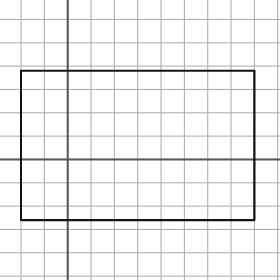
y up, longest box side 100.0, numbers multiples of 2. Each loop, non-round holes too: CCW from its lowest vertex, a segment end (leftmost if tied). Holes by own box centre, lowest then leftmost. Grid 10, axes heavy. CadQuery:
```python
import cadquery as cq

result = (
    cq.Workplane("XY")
    .moveTo(-20.0, -26.0)
    .lineTo(80.0, -26.0)
    .lineTo(80.0, 38.0)
    .lineTo(-20.0, 38.0)
    .close()
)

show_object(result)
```